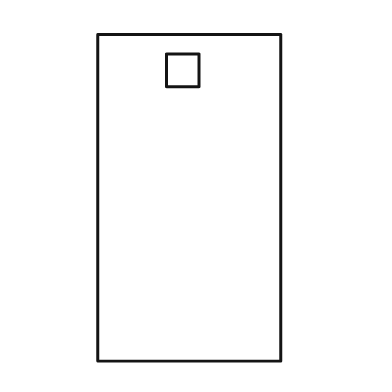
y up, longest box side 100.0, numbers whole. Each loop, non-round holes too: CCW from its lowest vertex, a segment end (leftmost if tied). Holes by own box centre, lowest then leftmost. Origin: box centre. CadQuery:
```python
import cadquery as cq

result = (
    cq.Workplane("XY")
    .moveTo(-28.0, -50.0)
    .lineTo(28.0, -50.0)
    .lineTo(28.0, 50.0)
    .lineTo(-28.0, 50.0)
    .close()
    .moveTo(-7.0, 34.0)
    .lineTo(3.0, 34.0)
    .lineTo(3.0, 44.0)
    .lineTo(-7.0, 44.0)
    .close()
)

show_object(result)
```